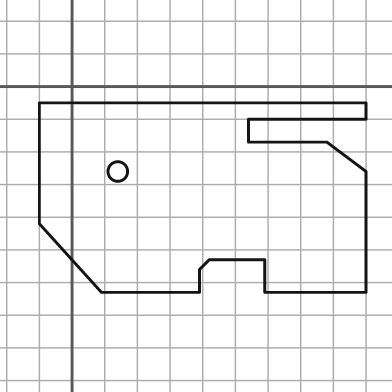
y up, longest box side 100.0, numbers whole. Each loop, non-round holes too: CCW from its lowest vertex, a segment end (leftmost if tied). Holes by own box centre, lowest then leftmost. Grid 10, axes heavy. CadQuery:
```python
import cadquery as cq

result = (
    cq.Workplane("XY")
    .moveTo(9.0, -63.0)
    .lineTo(39.0, -63.0)
    .lineTo(39.0, -56.0)
    .lineTo(42.0, -53.0)
    .lineTo(59.0, -53.0)
    .lineTo(59.0, -63.0)
    .lineTo(90.0, -63.0)
    .lineTo(90.0, -26.0)
    .lineTo(78.0, -17.0)
    .lineTo(54.0, -17.0)
    .lineTo(54.0, -10.0)
    .lineTo(90.0, -10.0)
    .lineTo(90.0, -5.0)
    .lineTo(-10.0, -5.0)
    .lineTo(-10.0, -42.0)
    .close()
    .moveTo(14.0, -26.0)
    .circle(3.0)
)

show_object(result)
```